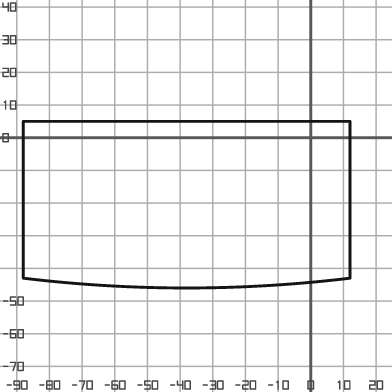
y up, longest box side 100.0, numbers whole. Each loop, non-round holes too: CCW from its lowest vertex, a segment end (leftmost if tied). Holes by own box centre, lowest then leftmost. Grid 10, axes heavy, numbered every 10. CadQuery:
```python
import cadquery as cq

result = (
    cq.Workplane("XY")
    .moveTo(-88.0, -43.0)
    .threePointArc((-38.0, -46.0), (12.0, -43.0))
    .lineTo(12.0, 5.0)
    .lineTo(-88.0, 5.0)
    .close()
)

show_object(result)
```